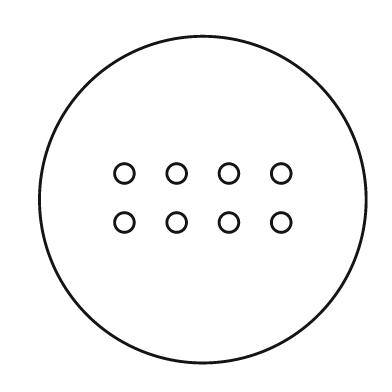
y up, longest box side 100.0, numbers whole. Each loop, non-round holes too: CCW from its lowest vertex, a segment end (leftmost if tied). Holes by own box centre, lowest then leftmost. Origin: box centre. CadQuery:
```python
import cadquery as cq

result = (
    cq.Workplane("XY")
    .moveTo(0.0, 0.0)
    .circle(50.0)
    .moveTo(-24.0, -7.0)
    .circle(3.0)
    .moveTo(-8.0, -7.0)
    .circle(3.0)
    .moveTo(8.0, -7.0)
    .circle(3.0)
    .moveTo(24.0, -7.0)
    .circle(3.0)
    .moveTo(-24.0, 8.0)
    .circle(3.0)
    .moveTo(-8.0, 8.0)
    .circle(3.0)
    .moveTo(8.0, 8.0)
    .circle(3.0)
    .moveTo(24.0, 8.0)
    .circle(3.0)
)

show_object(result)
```